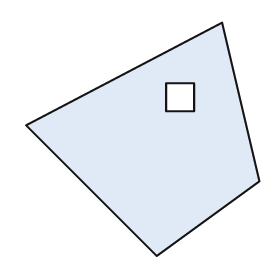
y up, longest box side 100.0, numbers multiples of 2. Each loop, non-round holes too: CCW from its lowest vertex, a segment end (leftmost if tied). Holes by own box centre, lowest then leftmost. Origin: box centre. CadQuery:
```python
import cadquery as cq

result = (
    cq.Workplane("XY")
    .moveTo(6.0, -50.0)
    .lineTo(50.0, -18.0)
    .lineTo(34.0, 50.0)
    .lineTo(-50.0, 6.0)
    .close()
    .moveTo(10.0, 12.0)
    .lineTo(22.0, 12.0)
    .lineTo(22.0, 24.0)
    .lineTo(10.0, 24.0)
    .close()
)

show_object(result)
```